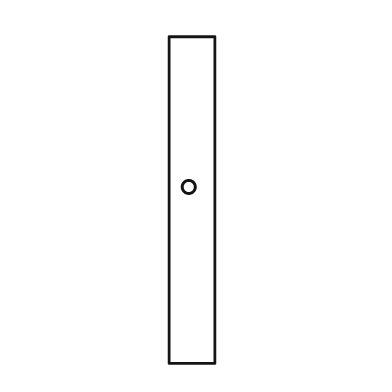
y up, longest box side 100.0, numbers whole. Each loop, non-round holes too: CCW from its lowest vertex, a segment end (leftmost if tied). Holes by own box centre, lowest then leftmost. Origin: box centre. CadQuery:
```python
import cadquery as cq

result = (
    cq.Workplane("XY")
    .moveTo(-7.0, -50.0)
    .lineTo(7.0, -50.0)
    .lineTo(7.0, 50.0)
    .lineTo(-7.0, 50.0)
    .close()
    .moveTo(-1.0, 4.0)
    .circle(2.0)
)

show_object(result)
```